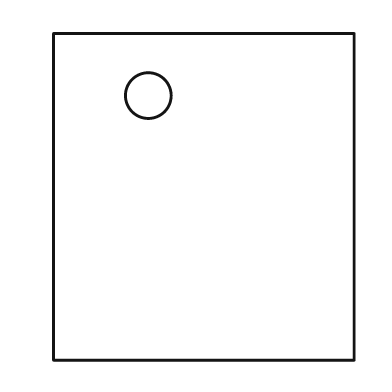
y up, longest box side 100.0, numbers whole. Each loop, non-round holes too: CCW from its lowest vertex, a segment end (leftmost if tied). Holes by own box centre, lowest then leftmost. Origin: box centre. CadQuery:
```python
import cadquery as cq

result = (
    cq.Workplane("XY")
    .moveTo(-46.0, -50.0)
    .lineTo(46.0, -50.0)
    .lineTo(46.0, 50.0)
    .lineTo(-46.0, 50.0)
    .close()
    .moveTo(-17.0, 31.0)
    .circle(7.0)
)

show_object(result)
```